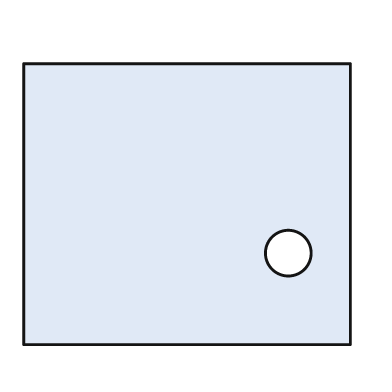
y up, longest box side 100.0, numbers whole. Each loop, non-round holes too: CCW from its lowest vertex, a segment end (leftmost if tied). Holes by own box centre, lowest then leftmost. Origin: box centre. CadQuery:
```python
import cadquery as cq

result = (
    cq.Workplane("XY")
    .moveTo(-50.0, -43.0)
    .lineTo(50.0, -43.0)
    .lineTo(50.0, 43.0)
    .lineTo(-50.0, 43.0)
    .close()
    .moveTo(31.0, -15.0)
    .circle(7.0)
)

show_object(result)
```